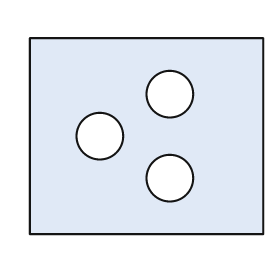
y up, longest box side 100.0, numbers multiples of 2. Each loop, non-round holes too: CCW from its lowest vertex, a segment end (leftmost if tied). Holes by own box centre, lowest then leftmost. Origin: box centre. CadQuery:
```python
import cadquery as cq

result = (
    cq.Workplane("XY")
    .moveTo(-50.0, -42.0)
    .lineTo(50.0, -42.0)
    .lineTo(50.0, 42.0)
    .lineTo(-50.0, 42.0)
    .close()
    .moveTo(10.0, -18.0)
    .circle(10.0)
    .moveTo(-20.0, 0.0)
    .circle(10.0)
    .moveTo(10.0, 18.0)
    .circle(10.0)
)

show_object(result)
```